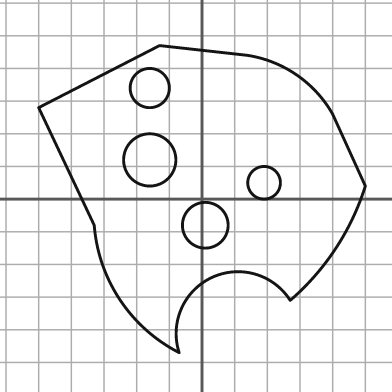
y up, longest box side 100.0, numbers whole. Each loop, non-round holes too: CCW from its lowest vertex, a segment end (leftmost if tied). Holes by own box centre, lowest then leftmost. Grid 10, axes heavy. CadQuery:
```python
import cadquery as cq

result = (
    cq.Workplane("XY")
    .moveTo(-7.0, -47.0)
    .threePointArc((3.0, -24.0), (27.0, -31.0))
    .threePointArc((41.0, -15.0), (50.0, 4.0))
    .lineTo(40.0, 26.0)
    .threePointArc((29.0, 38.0), (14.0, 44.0))
    .lineTo(-13.0, 47.0)
    .lineTo(-50.0, 28.0)
    .lineTo(-33.0, -8.0)
    .threePointArc((-25.0, -31.0), (-7.0, -47.0))
    .close()
    .moveTo(1.0, -8.0)
    .circle(7.0)
    .moveTo(19.0, 5.0)
    .circle(5.0)
    .moveTo(-16.0, 12.0)
    .circle(8.0)
    .moveTo(-16.0, 34.0)
    .circle(6.0)
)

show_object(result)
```